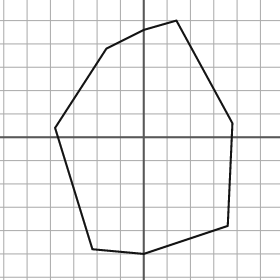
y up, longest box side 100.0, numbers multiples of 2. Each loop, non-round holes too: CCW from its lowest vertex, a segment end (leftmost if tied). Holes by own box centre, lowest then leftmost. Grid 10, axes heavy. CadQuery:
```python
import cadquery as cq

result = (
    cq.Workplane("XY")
    .moveTo(0.0, -50.0)
    .lineTo(36.0, -38.0)
    .lineTo(38.0, 6.0)
    .lineTo(14.0, 50.0)
    .lineTo(0.0, 46.0)
    .lineTo(-16.0, 38.0)
    .lineTo(-38.0, 4.0)
    .lineTo(-22.0, -48.0)
    .close()
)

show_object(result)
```